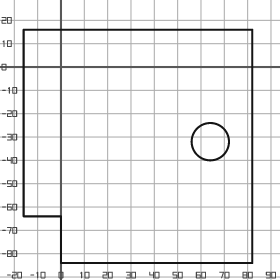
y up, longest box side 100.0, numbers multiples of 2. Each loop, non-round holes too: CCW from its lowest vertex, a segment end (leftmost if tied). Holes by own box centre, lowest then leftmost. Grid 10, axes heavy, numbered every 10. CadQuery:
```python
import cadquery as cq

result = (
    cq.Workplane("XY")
    .moveTo(0.0, -84.0)
    .lineTo(82.0, -84.0)
    .lineTo(82.0, 16.0)
    .lineTo(-16.0, 16.0)
    .lineTo(-16.0, -64.0)
    .lineTo(0.0, -64.0)
    .close()
    .moveTo(64.0, -32.0)
    .circle(8.0)
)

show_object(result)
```